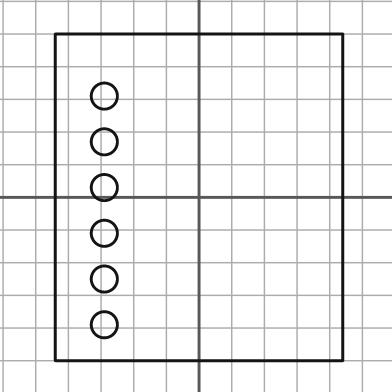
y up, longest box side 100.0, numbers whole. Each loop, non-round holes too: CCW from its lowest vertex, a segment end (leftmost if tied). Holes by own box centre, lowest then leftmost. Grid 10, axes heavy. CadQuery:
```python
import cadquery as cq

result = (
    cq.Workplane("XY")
    .moveTo(-44.0, -50.0)
    .lineTo(44.0, -50.0)
    .lineTo(44.0, 50.0)
    .lineTo(-44.0, 50.0)
    .close()
    .moveTo(-29.0, -39.0)
    .circle(4.0)
    .moveTo(-29.0, -25.0)
    .circle(4.0)
    .moveTo(-29.0, -11.0)
    .circle(4.0)
    .moveTo(-29.0, 3.0)
    .circle(4.0)
    .moveTo(-29.0, 17.0)
    .circle(4.0)
    .moveTo(-29.0, 31.0)
    .circle(4.0)
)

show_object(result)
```